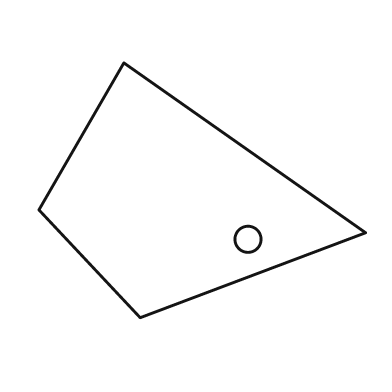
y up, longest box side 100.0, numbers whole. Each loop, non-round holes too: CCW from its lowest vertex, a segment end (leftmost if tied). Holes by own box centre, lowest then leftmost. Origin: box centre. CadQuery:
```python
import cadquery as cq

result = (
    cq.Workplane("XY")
    .moveTo(-19.0, -39.0)
    .lineTo(50.0, -13.0)
    .lineTo(-24.0, 39.0)
    .lineTo(-50.0, -6.0)
    .close()
    .moveTo(14.0, -15.0)
    .circle(4.0)
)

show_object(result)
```